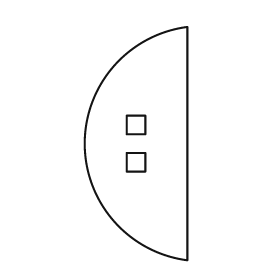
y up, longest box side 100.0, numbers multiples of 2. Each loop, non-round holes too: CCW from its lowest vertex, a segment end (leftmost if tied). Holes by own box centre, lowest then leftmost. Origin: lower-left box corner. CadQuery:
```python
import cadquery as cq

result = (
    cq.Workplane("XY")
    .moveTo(44.0, 0.0)
    .lineTo(44.0, 100.0)
    .threePointArc((0.0, 50.0), (44.0, 0.0))
    .close()
    .moveTo(18.0, 38.0)
    .lineTo(26.0, 38.0)
    .lineTo(26.0, 46.0)
    .lineTo(18.0, 46.0)
    .close()
    .moveTo(18.0, 54.0)
    .lineTo(26.0, 54.0)
    .lineTo(26.0, 62.0)
    .lineTo(18.0, 62.0)
    .close()
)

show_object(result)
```